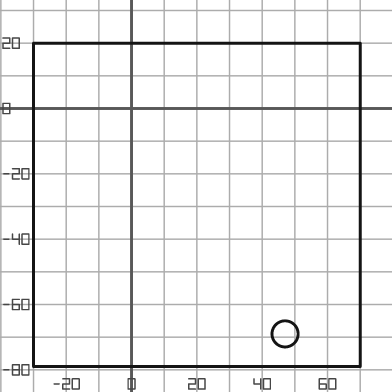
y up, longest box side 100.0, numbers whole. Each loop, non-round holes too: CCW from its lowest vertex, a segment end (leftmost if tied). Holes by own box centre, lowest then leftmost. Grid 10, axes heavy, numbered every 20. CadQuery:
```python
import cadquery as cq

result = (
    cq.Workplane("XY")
    .moveTo(-30.0, -79.0)
    .lineTo(70.0, -79.0)
    .lineTo(70.0, 20.0)
    .lineTo(-30.0, 20.0)
    .close()
    .moveTo(47.0, -69.0)
    .circle(4.0)
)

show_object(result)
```